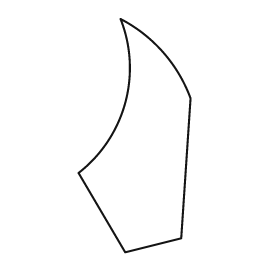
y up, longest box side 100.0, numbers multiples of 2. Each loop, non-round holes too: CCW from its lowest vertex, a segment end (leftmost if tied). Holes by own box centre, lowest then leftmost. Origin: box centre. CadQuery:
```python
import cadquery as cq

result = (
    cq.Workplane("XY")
    .moveTo(-4.0, -50.0)
    .lineTo(20.0, -44.0)
    .lineTo(24.0, 16.0)
    .threePointArc((12.0, 36.0), (-6.0, 50.0))
    .threePointArc((-4.0, 14.0), (-24.0, -16.0))
    .close()
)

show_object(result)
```